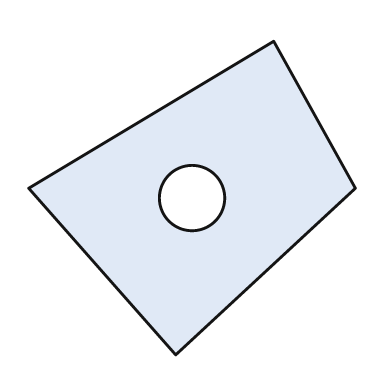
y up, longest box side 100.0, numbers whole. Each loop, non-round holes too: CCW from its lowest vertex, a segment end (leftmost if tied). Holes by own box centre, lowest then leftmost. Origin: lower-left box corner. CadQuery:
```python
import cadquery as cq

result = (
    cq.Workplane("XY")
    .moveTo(45.0, 0.0)
    .lineTo(100.0, 51.0)
    .lineTo(75.0, 96.0)
    .lineTo(0.0, 51.0)
    .close()
    .moveTo(50.0, 48.0)
    .circle(10.0)
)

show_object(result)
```